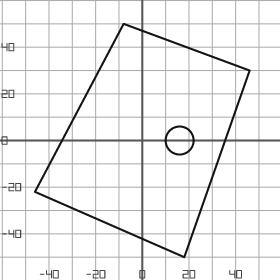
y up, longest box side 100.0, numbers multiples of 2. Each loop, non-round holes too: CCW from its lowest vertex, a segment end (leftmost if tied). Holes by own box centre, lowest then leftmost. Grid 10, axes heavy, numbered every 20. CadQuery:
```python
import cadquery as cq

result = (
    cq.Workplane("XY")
    .moveTo(18.0, -50.0)
    .lineTo(46.0, 30.0)
    .lineTo(-8.0, 50.0)
    .lineTo(-46.0, -22.0)
    .close()
    .moveTo(16.0, 0.0)
    .circle(6.0)
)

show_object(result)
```